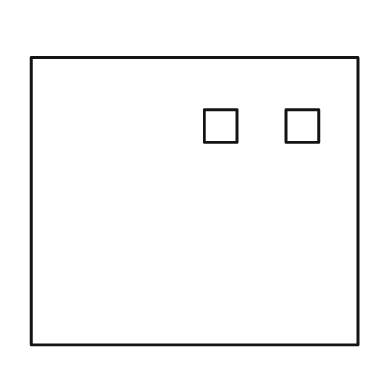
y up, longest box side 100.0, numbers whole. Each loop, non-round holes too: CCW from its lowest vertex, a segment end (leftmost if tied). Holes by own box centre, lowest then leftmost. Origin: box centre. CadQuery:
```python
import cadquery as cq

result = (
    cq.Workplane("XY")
    .moveTo(-50.0, -44.0)
    .lineTo(50.0, -44.0)
    .lineTo(50.0, 44.0)
    .lineTo(-50.0, 44.0)
    .close()
    .moveTo(3.0, 18.0)
    .lineTo(13.0, 18.0)
    .lineTo(13.0, 28.0)
    .lineTo(3.0, 28.0)
    .close()
    .moveTo(28.0, 18.0)
    .lineTo(38.0, 18.0)
    .lineTo(38.0, 28.0)
    .lineTo(28.0, 28.0)
    .close()
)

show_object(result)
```